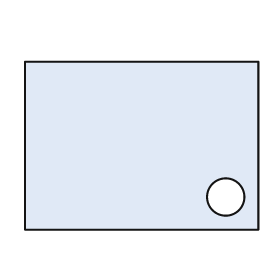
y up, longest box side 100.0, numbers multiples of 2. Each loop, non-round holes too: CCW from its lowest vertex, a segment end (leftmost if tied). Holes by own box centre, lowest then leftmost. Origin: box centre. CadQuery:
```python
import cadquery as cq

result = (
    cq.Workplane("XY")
    .moveTo(-50.0, -36.0)
    .lineTo(50.0, -36.0)
    .lineTo(50.0, 36.0)
    .lineTo(-50.0, 36.0)
    .close()
    .moveTo(36.0, -22.0)
    .circle(8.0)
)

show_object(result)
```